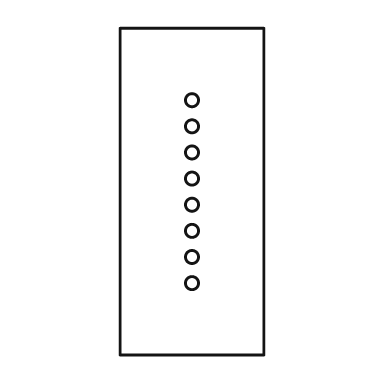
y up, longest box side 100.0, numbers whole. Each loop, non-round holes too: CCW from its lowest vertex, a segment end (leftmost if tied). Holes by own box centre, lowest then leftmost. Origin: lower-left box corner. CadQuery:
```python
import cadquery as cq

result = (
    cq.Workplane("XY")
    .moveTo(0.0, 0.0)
    .lineTo(44.0, 0.0)
    .lineTo(44.0, 100.0)
    .lineTo(0.0, 100.0)
    .close()
    .moveTo(22.0, 22.0)
    .circle(2.0)
    .moveTo(22.0, 30.0)
    .circle(2.0)
    .moveTo(22.0, 38.0)
    .circle(2.0)
    .moveTo(22.0, 46.0)
    .circle(2.0)
    .moveTo(22.0, 54.0)
    .circle(2.0)
    .moveTo(22.0, 62.0)
    .circle(2.0)
    .moveTo(22.0, 70.0)
    .circle(2.0)
    .moveTo(22.0, 78.0)
    .circle(2.0)
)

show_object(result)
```